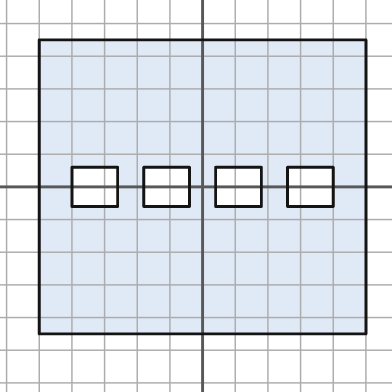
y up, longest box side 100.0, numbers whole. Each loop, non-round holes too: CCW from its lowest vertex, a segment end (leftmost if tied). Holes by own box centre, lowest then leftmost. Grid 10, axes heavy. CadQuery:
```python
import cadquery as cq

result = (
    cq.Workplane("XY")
    .moveTo(-50.0, -45.0)
    .lineTo(50.0, -45.0)
    .lineTo(50.0, 45.0)
    .lineTo(-50.0, 45.0)
    .close()
    .moveTo(-40.0, -6.0)
    .lineTo(-26.0, -6.0)
    .lineTo(-26.0, 6.0)
    .lineTo(-40.0, 6.0)
    .close()
    .moveTo(-18.0, -6.0)
    .lineTo(-4.0, -6.0)
    .lineTo(-4.0, 6.0)
    .lineTo(-18.0, 6.0)
    .close()
    .moveTo(4.0, -6.0)
    .lineTo(18.0, -6.0)
    .lineTo(18.0, 6.0)
    .lineTo(4.0, 6.0)
    .close()
    .moveTo(26.0, -6.0)
    .lineTo(40.0, -6.0)
    .lineTo(40.0, 6.0)
    .lineTo(26.0, 6.0)
    .close()
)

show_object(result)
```